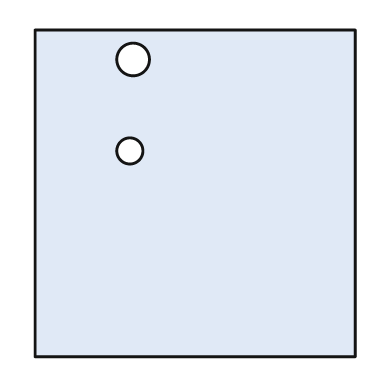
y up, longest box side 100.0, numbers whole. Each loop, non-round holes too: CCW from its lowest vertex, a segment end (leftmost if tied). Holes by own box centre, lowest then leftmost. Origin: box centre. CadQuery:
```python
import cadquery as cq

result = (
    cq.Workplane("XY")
    .moveTo(-49.0, -50.0)
    .lineTo(49.0, -50.0)
    .lineTo(49.0, 50.0)
    .lineTo(-49.0, 50.0)
    .close()
    .moveTo(-20.0, 13.0)
    .circle(4.0)
    .moveTo(-19.0, 41.0)
    .circle(5.0)
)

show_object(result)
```